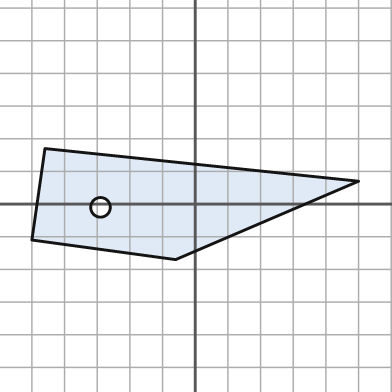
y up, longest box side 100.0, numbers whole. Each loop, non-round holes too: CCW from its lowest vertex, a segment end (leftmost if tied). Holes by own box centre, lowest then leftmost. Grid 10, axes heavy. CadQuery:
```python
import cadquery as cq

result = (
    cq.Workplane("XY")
    .moveTo(-6.0, -17.0)
    .lineTo(50.0, 7.0)
    .lineTo(-46.0, 17.0)
    .lineTo(-50.0, -11.0)
    .close()
    .moveTo(-29.0, -1.0)
    .circle(3.0)
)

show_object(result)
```